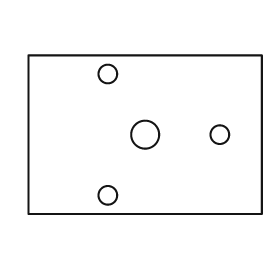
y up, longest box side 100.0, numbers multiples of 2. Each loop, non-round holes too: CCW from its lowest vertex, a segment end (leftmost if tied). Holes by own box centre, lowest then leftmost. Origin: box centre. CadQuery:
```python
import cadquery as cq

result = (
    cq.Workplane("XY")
    .moveTo(-50.0, -34.0)
    .lineTo(50.0, -34.0)
    .lineTo(50.0, 34.0)
    .lineTo(-50.0, 34.0)
    .close()
    .moveTo(-16.0, -26.0)
    .circle(4.0)
    .moveTo(0.0, 0.0)
    .circle(6.0)
    .moveTo(32.0, 0.0)
    .circle(4.0)
    .moveTo(-16.0, 26.0)
    .circle(4.0)
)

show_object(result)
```